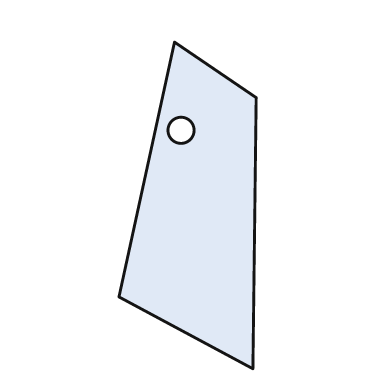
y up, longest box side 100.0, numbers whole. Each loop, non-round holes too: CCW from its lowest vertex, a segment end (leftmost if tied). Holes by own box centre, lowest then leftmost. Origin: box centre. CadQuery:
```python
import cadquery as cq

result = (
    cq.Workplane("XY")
    .moveTo(20.0, -50.0)
    .lineTo(21.0, 33.0)
    .lineTo(-4.0, 50.0)
    .lineTo(-21.0, -28.0)
    .close()
    .moveTo(-2.0, 23.0)
    .circle(4.0)
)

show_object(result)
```